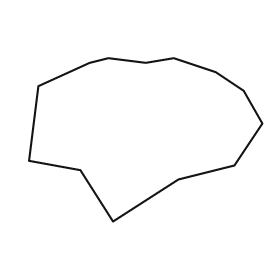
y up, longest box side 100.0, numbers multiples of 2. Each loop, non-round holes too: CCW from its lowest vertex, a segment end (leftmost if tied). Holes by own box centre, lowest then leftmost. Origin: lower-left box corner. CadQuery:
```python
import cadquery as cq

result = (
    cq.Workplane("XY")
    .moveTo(36.0, 0.0)
    .lineTo(64.0, 18.0)
    .lineTo(88.0, 24.0)
    .lineTo(100.0, 42.0)
    .lineTo(92.0, 56.0)
    .lineTo(80.0, 64.0)
    .lineTo(62.0, 70.0)
    .lineTo(50.0, 68.0)
    .lineTo(34.0, 70.0)
    .lineTo(26.0, 68.0)
    .lineTo(4.0, 58.0)
    .lineTo(0.0, 26.0)
    .lineTo(22.0, 22.0)
    .close()
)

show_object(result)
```